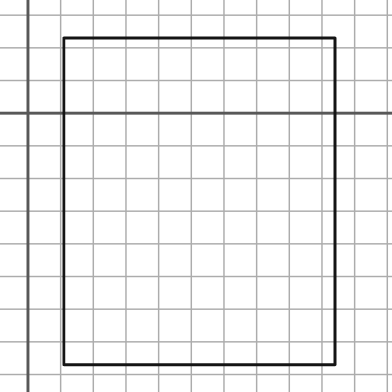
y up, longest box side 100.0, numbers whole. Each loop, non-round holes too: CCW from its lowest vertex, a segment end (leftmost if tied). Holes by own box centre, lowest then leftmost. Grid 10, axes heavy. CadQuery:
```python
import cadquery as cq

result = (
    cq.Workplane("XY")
    .moveTo(11.0, -77.0)
    .lineTo(94.0, -77.0)
    .lineTo(94.0, 23.0)
    .lineTo(11.0, 23.0)
    .close()
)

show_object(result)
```